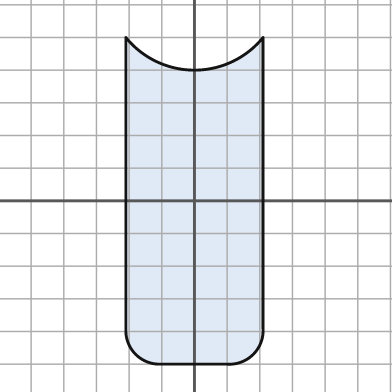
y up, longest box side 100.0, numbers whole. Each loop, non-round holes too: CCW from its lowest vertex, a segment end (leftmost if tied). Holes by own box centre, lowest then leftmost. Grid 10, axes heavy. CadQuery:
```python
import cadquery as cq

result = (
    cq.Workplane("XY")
    .moveTo(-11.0, -50.0)
    .lineTo(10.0, -50.0)
    .threePointArc((18.0, -47.0), (21.0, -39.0))
    .lineTo(21.0, 50.0)
    .threePointArc((0.0, 40.0), (-21.0, 50.0))
    .lineTo(-21.0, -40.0)
    .threePointArc((-18.0, -47.0), (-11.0, -50.0))
    .close()
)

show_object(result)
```